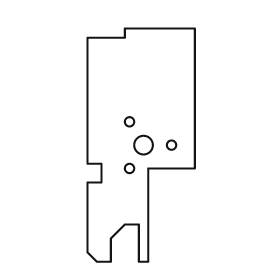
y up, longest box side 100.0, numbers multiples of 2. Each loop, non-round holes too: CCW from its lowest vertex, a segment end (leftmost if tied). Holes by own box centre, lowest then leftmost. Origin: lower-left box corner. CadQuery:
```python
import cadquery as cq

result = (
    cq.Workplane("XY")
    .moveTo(4.0, 0.0)
    .lineTo(10.0, 0.0)
    .lineTo(10.0, 10.0)
    .lineTo(16.0, 16.0)
    .lineTo(22.0, 16.0)
    .lineTo(22.0, 0.0)
    .lineTo(26.0, 0.0)
    .lineTo(26.0, 40.0)
    .lineTo(46.0, 40.0)
    .lineTo(46.0, 100.0)
    .lineTo(16.0, 100.0)
    .lineTo(16.0, 96.0)
    .lineTo(0.0, 96.0)
    .lineTo(0.0, 42.0)
    .lineTo(6.0, 42.0)
    .lineTo(6.0, 34.0)
    .lineTo(0.0, 34.0)
    .lineTo(0.0, 4.0)
    .close()
    .moveTo(18.0, 40.0)
    .circle(2.0)
    .moveTo(24.0, 50.0)
    .circle(4.0)
    .moveTo(36.0, 50.0)
    .circle(2.0)
    .moveTo(18.0, 60.0)
    .circle(2.0)
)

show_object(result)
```